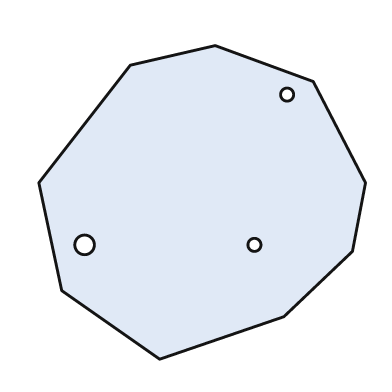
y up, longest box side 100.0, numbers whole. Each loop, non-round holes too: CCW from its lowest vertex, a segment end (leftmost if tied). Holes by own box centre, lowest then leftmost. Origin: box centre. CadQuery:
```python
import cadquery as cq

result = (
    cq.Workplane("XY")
    .moveTo(-13.0, -48.0)
    .lineTo(25.0, -35.0)
    .lineTo(46.0, -15.0)
    .lineTo(50.0, 6.0)
    .lineTo(34.0, 37.0)
    .lineTo(4.0, 48.0)
    .lineTo(-22.0, 42.0)
    .lineTo(-50.0, 6.0)
    .lineTo(-43.0, -27.0)
    .close()
    .moveTo(-36.0, -13.0)
    .circle(3.0)
    .moveTo(16.0, -13.0)
    .circle(2.0)
    .moveTo(26.0, 33.0)
    .circle(2.0)
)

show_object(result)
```